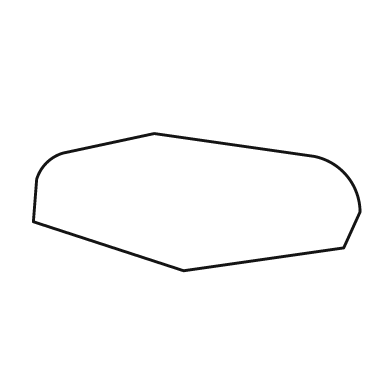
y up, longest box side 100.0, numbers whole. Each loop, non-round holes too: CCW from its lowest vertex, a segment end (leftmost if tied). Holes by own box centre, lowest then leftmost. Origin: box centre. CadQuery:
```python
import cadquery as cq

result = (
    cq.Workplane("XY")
    .moveTo(-4.0, -21.0)
    .lineTo(45.0, -14.0)
    .lineTo(50.0, -3.0)
    .threePointArc((46.0, 8.0), (36.0, 14.0))
    .lineTo(-13.0, 21.0)
    .lineTo(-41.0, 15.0)
    .threePointArc((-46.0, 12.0), (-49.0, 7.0))
    .lineTo(-50.0, -6.0)
    .close()
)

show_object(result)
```